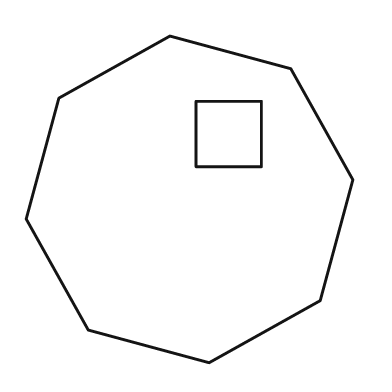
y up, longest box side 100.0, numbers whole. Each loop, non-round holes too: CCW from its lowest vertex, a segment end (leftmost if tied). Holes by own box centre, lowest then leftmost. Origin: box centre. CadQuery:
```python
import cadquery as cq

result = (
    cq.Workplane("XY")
    .moveTo(6.0, -50.0)
    .lineTo(40.0, -31.0)
    .lineTo(50.0, 6.0)
    .lineTo(31.0, 40.0)
    .lineTo(-6.0, 50.0)
    .lineTo(-40.0, 31.0)
    .lineTo(-50.0, -6.0)
    .lineTo(-31.0, -40.0)
    .close()
    .moveTo(2.0, 10.0)
    .lineTo(22.0, 10.0)
    .lineTo(22.0, 30.0)
    .lineTo(2.0, 30.0)
    .close()
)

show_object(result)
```